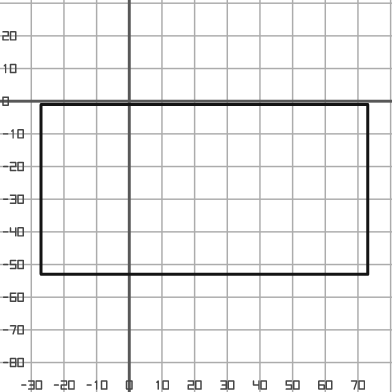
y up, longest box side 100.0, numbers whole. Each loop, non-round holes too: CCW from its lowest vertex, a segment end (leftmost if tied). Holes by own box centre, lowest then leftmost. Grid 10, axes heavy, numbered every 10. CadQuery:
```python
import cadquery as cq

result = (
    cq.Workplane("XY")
    .moveTo(-27.0, -53.0)
    .lineTo(73.0, -53.0)
    .lineTo(73.0, -1.0)
    .lineTo(-27.0, -1.0)
    .close()
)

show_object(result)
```